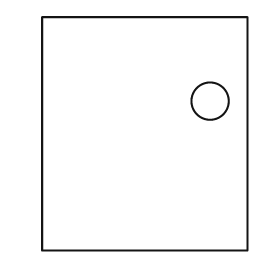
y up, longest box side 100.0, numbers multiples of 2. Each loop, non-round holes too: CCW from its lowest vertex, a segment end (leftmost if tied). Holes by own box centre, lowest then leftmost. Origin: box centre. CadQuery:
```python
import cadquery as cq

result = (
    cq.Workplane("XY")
    .moveTo(-44.0, -50.0)
    .lineTo(44.0, -50.0)
    .lineTo(44.0, 50.0)
    .lineTo(-44.0, 50.0)
    .close()
    .moveTo(28.0, 14.0)
    .circle(8.0)
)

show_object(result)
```